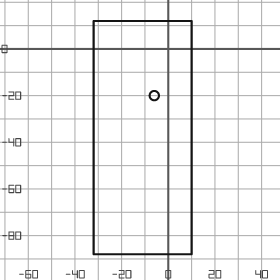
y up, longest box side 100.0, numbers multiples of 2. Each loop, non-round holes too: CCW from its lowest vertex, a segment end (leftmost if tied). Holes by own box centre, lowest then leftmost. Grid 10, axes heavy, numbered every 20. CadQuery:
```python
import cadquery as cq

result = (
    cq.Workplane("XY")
    .moveTo(-32.0, -88.0)
    .lineTo(10.0, -88.0)
    .lineTo(10.0, 12.0)
    .lineTo(-32.0, 12.0)
    .close()
    .moveTo(-6.0, -20.0)
    .circle(2.0)
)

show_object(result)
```